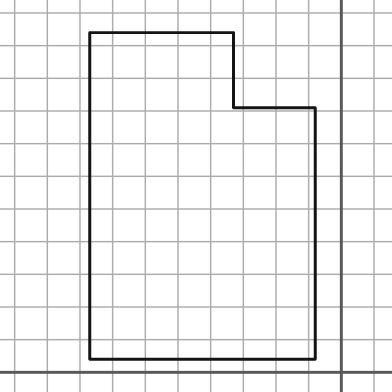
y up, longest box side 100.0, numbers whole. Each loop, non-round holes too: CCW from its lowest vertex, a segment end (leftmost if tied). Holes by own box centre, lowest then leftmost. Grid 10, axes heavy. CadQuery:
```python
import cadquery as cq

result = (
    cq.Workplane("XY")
    .moveTo(-77.0, 4.0)
    .lineTo(-8.0, 4.0)
    .lineTo(-8.0, 81.0)
    .lineTo(-33.0, 81.0)
    .lineTo(-33.0, 104.0)
    .lineTo(-77.0, 104.0)
    .close()
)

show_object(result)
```